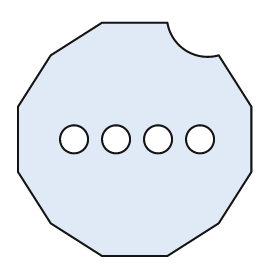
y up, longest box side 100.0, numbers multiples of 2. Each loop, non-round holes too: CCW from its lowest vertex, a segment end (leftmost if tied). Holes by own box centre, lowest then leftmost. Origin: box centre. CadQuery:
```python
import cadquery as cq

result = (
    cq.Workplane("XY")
    .moveTo(-14.0, -50.0)
    .lineTo(14.0, -50.0)
    .lineTo(36.0, -36.0)
    .lineTo(50.0, -14.0)
    .lineTo(50.0, 14.0)
    .lineTo(36.0, 36.0)
    .threePointArc((22.0, 38.0), (14.0, 50.0))
    .lineTo(-14.0, 50.0)
    .lineTo(-36.0, 36.0)
    .lineTo(-50.0, 14.0)
    .lineTo(-50.0, -14.0)
    .lineTo(-36.0, -36.0)
    .close()
    .moveTo(-26.0, 0.0)
    .circle(6.0)
    .moveTo(-8.0, 0.0)
    .circle(6.0)
    .moveTo(10.0, 0.0)
    .circle(6.0)
    .moveTo(28.0, 0.0)
    .circle(6.0)
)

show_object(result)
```